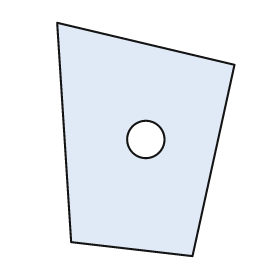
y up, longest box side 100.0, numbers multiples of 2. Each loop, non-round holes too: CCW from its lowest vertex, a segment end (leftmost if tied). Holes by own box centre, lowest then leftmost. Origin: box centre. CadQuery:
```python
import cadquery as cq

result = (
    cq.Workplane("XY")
    .moveTo(20.0, -50.0)
    .lineTo(38.0, 32.0)
    .lineTo(-38.0, 50.0)
    .lineTo(-32.0, -44.0)
    .close()
    .moveTo(0.0, 0.0)
    .circle(8.0)
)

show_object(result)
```